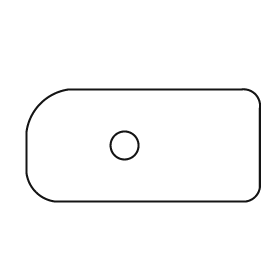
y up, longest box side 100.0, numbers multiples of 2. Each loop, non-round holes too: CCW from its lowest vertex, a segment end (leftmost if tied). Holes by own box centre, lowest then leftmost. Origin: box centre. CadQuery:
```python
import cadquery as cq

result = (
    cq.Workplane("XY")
    .moveTo(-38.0, -24.0)
    .lineTo(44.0, -24.0)
    .threePointArc((48.0, -22.0), (50.0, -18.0))
    .lineTo(50.0, 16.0)
    .threePointArc((48.0, 22.0), (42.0, 24.0))
    .lineTo(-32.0, 24.0)
    .threePointArc((-44.0, 18.0), (-50.0, 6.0))
    .lineTo(-50.0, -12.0)
    .threePointArc((-46.0, -20.0), (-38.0, -24.0))
    .close()
    .moveTo(-8.0, 0.0)
    .circle(6.0)
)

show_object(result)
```